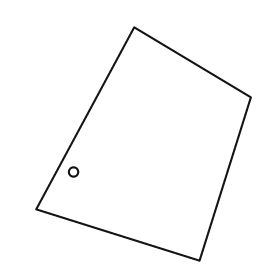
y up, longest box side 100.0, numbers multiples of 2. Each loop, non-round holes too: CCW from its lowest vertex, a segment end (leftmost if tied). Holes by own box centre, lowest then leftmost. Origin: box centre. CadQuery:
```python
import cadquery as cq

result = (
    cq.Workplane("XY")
    .moveTo(24.0, -50.0)
    .lineTo(46.0, 20.0)
    .lineTo(-4.0, 50.0)
    .lineTo(-46.0, -28.0)
    .close()
    .moveTo(-30.0, -12.0)
    .circle(2.0)
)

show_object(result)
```